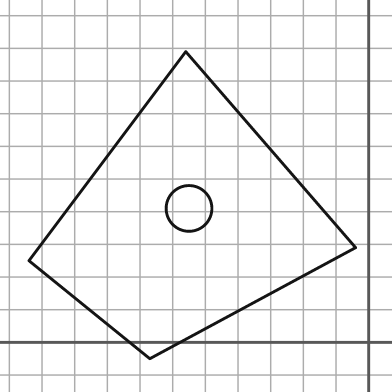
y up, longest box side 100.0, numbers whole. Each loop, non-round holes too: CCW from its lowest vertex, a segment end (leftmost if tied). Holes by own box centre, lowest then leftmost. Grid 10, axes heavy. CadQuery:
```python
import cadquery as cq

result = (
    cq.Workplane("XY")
    .moveTo(-67.0, -5.0)
    .lineTo(-4.0, 29.0)
    .lineTo(-56.0, 89.0)
    .lineTo(-104.0, 25.0)
    .close()
    .moveTo(-55.0, 41.0)
    .circle(7.0)
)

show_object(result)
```